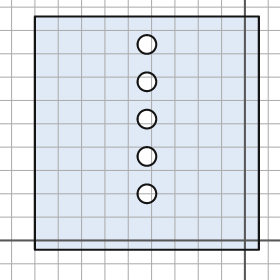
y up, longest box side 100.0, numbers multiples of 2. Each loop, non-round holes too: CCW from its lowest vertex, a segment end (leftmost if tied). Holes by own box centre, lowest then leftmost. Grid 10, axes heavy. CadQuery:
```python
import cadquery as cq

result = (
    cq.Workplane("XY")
    .moveTo(-90.0, -4.0)
    .lineTo(6.0, -4.0)
    .lineTo(6.0, 96.0)
    .lineTo(-90.0, 96.0)
    .close()
    .moveTo(-42.0, 20.0)
    .circle(4.0)
    .moveTo(-42.0, 36.0)
    .circle(4.0)
    .moveTo(-42.0, 52.0)
    .circle(4.0)
    .moveTo(-42.0, 68.0)
    .circle(4.0)
    .moveTo(-42.0, 84.0)
    .circle(4.0)
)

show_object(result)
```